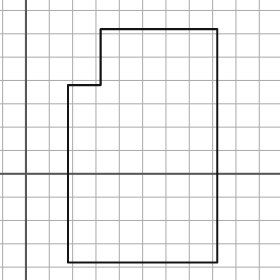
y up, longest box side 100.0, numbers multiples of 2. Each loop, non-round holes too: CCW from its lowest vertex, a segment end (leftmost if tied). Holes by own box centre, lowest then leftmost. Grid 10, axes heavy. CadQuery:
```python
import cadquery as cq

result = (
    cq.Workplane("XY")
    .moveTo(18.0, -38.0)
    .lineTo(82.0, -38.0)
    .lineTo(82.0, 62.0)
    .lineTo(32.0, 62.0)
    .lineTo(32.0, 38.0)
    .lineTo(18.0, 38.0)
    .close()
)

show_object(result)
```